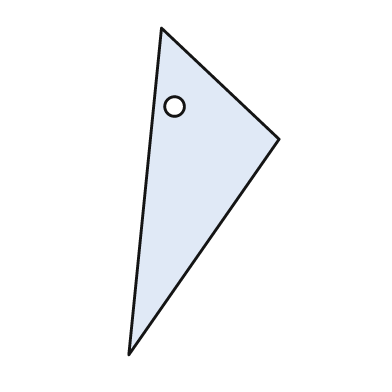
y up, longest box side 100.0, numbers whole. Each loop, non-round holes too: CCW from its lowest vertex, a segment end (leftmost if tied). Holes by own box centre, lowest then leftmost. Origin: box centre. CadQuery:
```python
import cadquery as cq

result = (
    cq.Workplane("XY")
    .moveTo(-23.0, -50.0)
    .lineTo(23.0, 16.0)
    .lineTo(-13.0, 50.0)
    .close()
    .moveTo(-9.0, 26.0)
    .circle(3.0)
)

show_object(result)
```